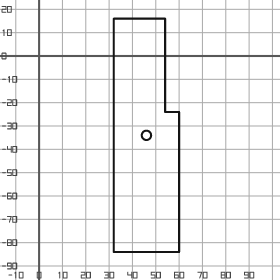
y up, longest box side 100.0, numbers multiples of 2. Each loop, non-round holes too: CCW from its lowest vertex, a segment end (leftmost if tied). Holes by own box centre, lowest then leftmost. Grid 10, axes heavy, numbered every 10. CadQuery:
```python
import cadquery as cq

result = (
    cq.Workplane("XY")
    .moveTo(32.0, -84.0)
    .lineTo(60.0, -84.0)
    .lineTo(60.0, -24.0)
    .lineTo(54.0, -24.0)
    .lineTo(54.0, 16.0)
    .lineTo(32.0, 16.0)
    .close()
    .moveTo(46.0, -34.0)
    .circle(2.0)
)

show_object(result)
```